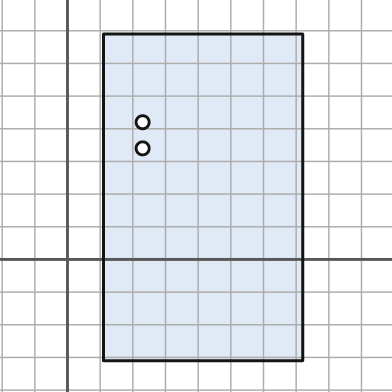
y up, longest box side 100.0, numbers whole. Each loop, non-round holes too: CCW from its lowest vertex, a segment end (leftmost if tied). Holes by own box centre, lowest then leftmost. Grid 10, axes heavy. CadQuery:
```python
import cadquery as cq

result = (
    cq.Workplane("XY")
    .moveTo(11.0, -31.0)
    .lineTo(72.0, -31.0)
    .lineTo(72.0, 69.0)
    .lineTo(11.0, 69.0)
    .close()
    .moveTo(23.0, 34.0)
    .circle(2.0)
    .moveTo(23.0, 42.0)
    .circle(2.0)
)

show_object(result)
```